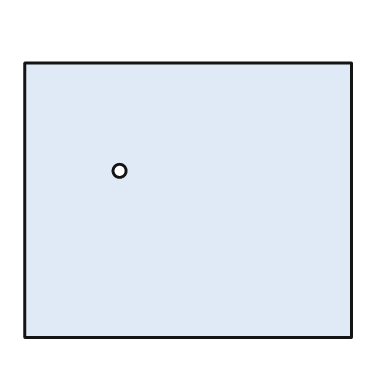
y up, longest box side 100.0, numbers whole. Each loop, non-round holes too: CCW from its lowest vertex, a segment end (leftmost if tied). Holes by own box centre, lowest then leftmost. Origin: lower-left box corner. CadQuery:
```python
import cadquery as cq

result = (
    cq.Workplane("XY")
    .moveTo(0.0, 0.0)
    .lineTo(100.0, 0.0)
    .lineTo(100.0, 84.0)
    .lineTo(0.0, 84.0)
    .close()
    .moveTo(29.0, 51.0)
    .circle(2.0)
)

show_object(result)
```